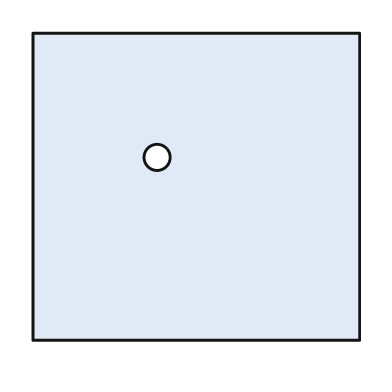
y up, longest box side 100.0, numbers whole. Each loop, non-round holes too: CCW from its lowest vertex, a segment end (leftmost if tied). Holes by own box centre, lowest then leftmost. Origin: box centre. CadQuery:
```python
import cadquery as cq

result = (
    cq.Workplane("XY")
    .moveTo(-50.0, -47.0)
    .lineTo(50.0, -47.0)
    .lineTo(50.0, 47.0)
    .lineTo(-50.0, 47.0)
    .close()
    .moveTo(-12.0, 9.0)
    .circle(4.0)
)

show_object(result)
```